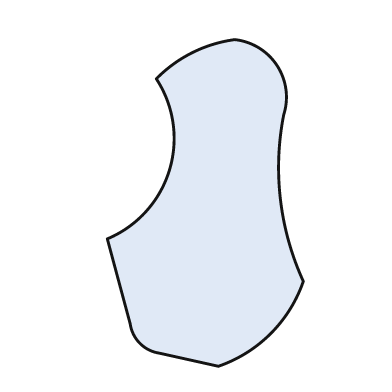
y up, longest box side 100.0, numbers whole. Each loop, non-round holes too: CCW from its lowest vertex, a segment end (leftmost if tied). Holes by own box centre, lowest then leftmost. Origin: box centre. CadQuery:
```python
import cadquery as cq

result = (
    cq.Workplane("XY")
    .moveTo(4.0, -50.0)
    .threePointArc((20.0, -40.0), (30.0, -24.0))
    .threePointArc((23.0, 1.0), (24.0, 27.0))
    .threePointArc((22.0, 42.0), (9.0, 50.0))
    .threePointArc((-4.0, 46.0), (-15.0, 38.0))
    .threePointArc((-11.0, 10.0), (-30.0, -11.0))
    .lineTo(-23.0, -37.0)
    .threePointArc((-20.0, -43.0), (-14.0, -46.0))
    .close()
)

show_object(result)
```